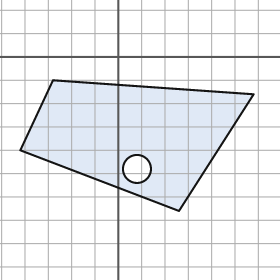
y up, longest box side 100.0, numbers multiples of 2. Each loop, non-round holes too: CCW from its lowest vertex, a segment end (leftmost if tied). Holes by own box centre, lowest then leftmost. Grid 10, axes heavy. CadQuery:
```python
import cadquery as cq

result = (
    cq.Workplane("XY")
    .moveTo(26.0, -66.0)
    .lineTo(58.0, -16.0)
    .lineTo(-28.0, -10.0)
    .lineTo(-42.0, -40.0)
    .close()
    .moveTo(8.0, -48.0)
    .circle(6.0)
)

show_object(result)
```